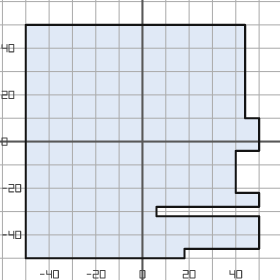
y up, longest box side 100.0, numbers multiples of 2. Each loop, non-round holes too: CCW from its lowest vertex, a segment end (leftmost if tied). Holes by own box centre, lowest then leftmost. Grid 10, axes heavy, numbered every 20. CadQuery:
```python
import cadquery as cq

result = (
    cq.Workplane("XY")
    .moveTo(-50.0, -50.0)
    .lineTo(18.0, -50.0)
    .lineTo(18.0, -46.0)
    .lineTo(50.0, -46.0)
    .lineTo(50.0, -32.0)
    .lineTo(6.0, -32.0)
    .lineTo(6.0, -28.0)
    .lineTo(50.0, -28.0)
    .lineTo(50.0, -22.0)
    .lineTo(40.0, -22.0)
    .lineTo(40.0, -4.0)
    .lineTo(50.0, -4.0)
    .lineTo(50.0, 10.0)
    .lineTo(44.0, 10.0)
    .lineTo(44.0, 50.0)
    .lineTo(-50.0, 50.0)
    .close()
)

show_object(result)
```